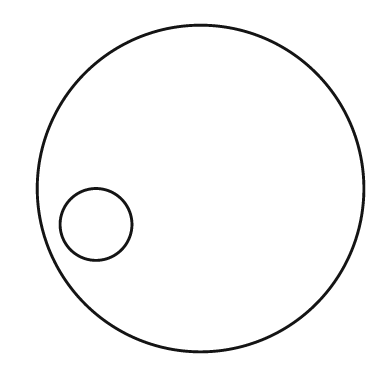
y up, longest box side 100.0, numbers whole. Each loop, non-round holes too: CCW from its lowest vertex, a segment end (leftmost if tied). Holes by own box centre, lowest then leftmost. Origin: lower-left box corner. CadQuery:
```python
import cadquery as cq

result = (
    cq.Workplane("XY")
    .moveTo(50.0, 50.0)
    .circle(50.0)
    .moveTo(18.0, 39.0)
    .circle(11.0)
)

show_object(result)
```